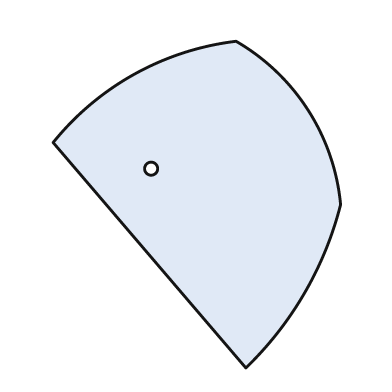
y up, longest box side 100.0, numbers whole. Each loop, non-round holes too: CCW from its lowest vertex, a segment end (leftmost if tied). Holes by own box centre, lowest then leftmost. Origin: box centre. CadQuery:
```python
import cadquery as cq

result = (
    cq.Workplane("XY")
    .moveTo(15.0, -50.0)
    .threePointArc((33.0, -27.0), (44.0, 0.0))
    .threePointArc((34.0, 29.0), (12.0, 50.0))
    .threePointArc((-19.0, 40.0), (-44.0, 19.0))
    .close()
    .moveTo(-14.0, 11.0)
    .circle(2.0)
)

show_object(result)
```